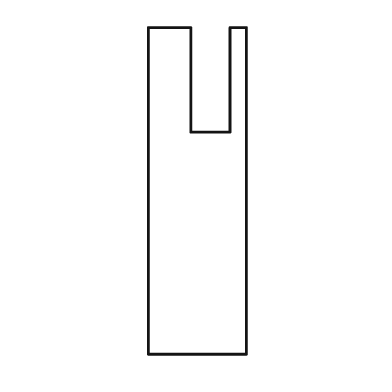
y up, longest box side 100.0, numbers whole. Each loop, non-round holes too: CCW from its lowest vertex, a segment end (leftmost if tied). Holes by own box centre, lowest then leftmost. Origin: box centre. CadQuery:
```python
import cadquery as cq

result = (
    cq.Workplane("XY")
    .moveTo(-15.0, -50.0)
    .lineTo(15.0, -50.0)
    .lineTo(15.0, 50.0)
    .lineTo(10.0, 50.0)
    .lineTo(10.0, 18.0)
    .lineTo(-2.0, 18.0)
    .lineTo(-2.0, 50.0)
    .lineTo(-15.0, 50.0)
    .close()
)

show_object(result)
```